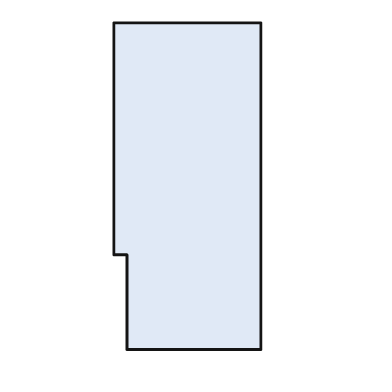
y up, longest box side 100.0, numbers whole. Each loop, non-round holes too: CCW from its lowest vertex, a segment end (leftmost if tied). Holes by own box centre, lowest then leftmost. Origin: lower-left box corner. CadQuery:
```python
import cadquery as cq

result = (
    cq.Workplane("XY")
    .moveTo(4.0, 0.0)
    .lineTo(45.0, 0.0)
    .lineTo(45.0, 100.0)
    .lineTo(0.0, 100.0)
    .lineTo(0.0, 29.0)
    .lineTo(4.0, 29.0)
    .close()
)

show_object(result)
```